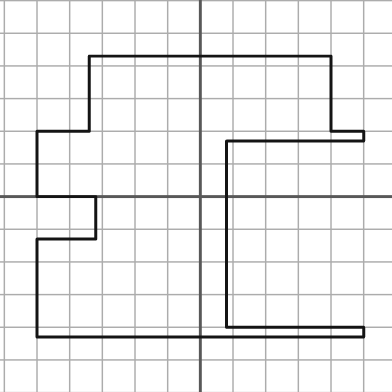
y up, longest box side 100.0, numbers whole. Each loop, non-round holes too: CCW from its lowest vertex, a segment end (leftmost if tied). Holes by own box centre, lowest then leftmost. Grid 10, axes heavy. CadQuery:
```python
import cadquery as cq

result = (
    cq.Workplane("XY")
    .moveTo(-50.0, -43.0)
    .lineTo(50.0, -43.0)
    .lineTo(50.0, -40.0)
    .lineTo(8.0, -40.0)
    .lineTo(8.0, 17.0)
    .lineTo(50.0, 17.0)
    .lineTo(50.0, 20.0)
    .lineTo(40.0, 20.0)
    .lineTo(40.0, 43.0)
    .lineTo(-34.0, 43.0)
    .lineTo(-34.0, 20.0)
    .lineTo(-50.0, 20.0)
    .lineTo(-50.0, 0.0)
    .lineTo(-32.0, 0.0)
    .lineTo(-32.0, -13.0)
    .lineTo(-50.0, -13.0)
    .close()
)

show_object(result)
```